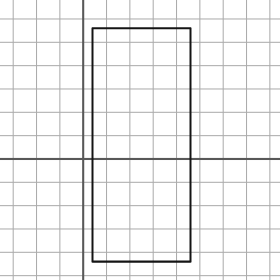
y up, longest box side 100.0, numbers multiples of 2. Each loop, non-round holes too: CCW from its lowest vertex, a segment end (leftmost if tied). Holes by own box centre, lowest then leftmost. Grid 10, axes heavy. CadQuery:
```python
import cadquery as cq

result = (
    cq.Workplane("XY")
    .moveTo(4.0, -44.0)
    .lineTo(46.0, -44.0)
    .lineTo(46.0, 56.0)
    .lineTo(4.0, 56.0)
    .close()
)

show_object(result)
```